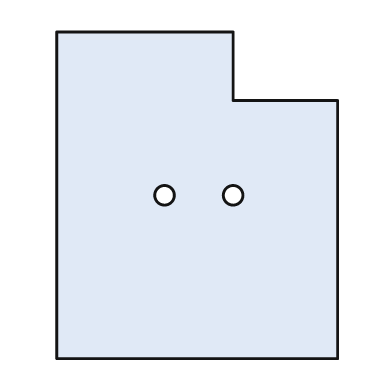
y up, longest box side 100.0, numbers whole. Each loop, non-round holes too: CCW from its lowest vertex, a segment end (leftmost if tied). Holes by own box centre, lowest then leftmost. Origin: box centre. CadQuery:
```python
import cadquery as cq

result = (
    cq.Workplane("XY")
    .moveTo(-43.0, -50.0)
    .lineTo(43.0, -50.0)
    .lineTo(43.0, 29.0)
    .lineTo(11.0, 29.0)
    .lineTo(11.0, 50.0)
    .lineTo(-43.0, 50.0)
    .close()
    .moveTo(-10.0, 0.0)
    .circle(3.0)
    .moveTo(11.0, 0.0)
    .circle(3.0)
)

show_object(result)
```